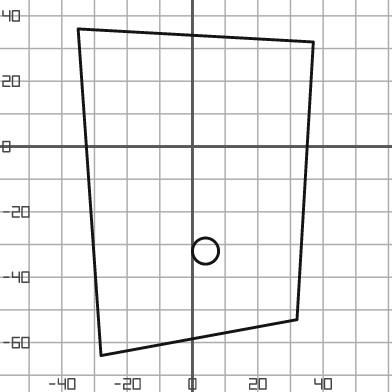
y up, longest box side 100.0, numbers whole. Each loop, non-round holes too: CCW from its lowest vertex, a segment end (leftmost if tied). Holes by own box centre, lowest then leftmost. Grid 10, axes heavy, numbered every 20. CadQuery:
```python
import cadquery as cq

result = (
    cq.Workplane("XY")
    .moveTo(-28.0, -64.0)
    .lineTo(32.0, -53.0)
    .lineTo(37.0, 32.0)
    .lineTo(-35.0, 36.0)
    .close()
    .moveTo(4.0, -32.0)
    .circle(4.0)
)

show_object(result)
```